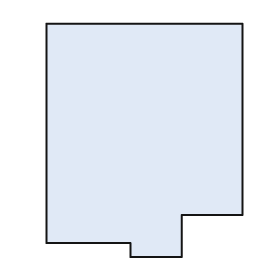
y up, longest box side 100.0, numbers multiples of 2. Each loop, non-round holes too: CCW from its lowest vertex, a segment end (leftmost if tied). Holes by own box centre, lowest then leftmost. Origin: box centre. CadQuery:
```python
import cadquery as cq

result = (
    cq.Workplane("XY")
    .moveTo(-6.0, -50.0)
    .lineTo(16.0, -50.0)
    .lineTo(16.0, -32.0)
    .lineTo(42.0, -32.0)
    .lineTo(42.0, 50.0)
    .lineTo(-42.0, 50.0)
    .lineTo(-42.0, -44.0)
    .lineTo(-6.0, -44.0)
    .close()
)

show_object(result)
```